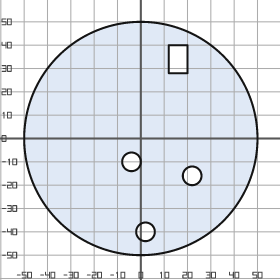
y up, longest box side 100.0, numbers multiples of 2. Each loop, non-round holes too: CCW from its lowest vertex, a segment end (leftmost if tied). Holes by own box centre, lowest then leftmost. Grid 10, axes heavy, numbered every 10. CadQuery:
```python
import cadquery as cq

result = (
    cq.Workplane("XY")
    .moveTo(0.0, 0.0)
    .circle(50.0)
    .moveTo(2.0, -40.0)
    .circle(4.0)
    .moveTo(22.0, -16.0)
    .circle(4.0)
    .moveTo(-4.0, -10.0)
    .circle(4.0)
    .moveTo(12.0, 28.0)
    .lineTo(20.0, 28.0)
    .lineTo(20.0, 40.0)
    .lineTo(12.0, 40.0)
    .close()
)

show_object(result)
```